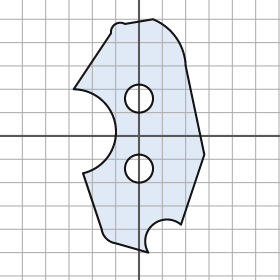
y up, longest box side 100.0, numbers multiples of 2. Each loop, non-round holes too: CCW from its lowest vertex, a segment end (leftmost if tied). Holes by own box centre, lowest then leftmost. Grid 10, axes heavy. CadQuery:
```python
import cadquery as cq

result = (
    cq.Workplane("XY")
    .moveTo(4.0, -50.0)
    .threePointArc((6.0, -38.0), (18.0, -38.0))
    .lineTo(28.0, -8.0)
    .lineTo(20.0, 30.0)
    .threePointArc((16.0, 42.0), (6.0, 50.0))
    .lineTo(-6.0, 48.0)
    .threePointArc((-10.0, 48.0), (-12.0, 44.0))
    .lineTo(-28.0, 20.0)
    .threePointArc((-10.0, 4.0), (-24.0, -16.0))
    .lineTo(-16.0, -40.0)
    .threePointArc((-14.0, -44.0), (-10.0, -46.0))
    .close()
    .moveTo(0.0, -14.0)
    .circle(6.0)
    .moveTo(0.0, 16.0)
    .circle(6.0)
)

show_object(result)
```